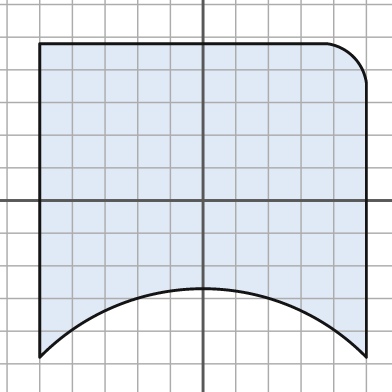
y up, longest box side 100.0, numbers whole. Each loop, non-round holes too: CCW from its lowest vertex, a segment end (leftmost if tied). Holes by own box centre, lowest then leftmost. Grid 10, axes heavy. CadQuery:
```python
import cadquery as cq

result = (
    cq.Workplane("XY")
    .moveTo(-50.0, -48.0)
    .threePointArc((0.0, -27.0), (50.0, -48.0))
    .lineTo(50.0, 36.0)
    .threePointArc((46.0, 44.0), (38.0, 48.0))
    .lineTo(-50.0, 48.0)
    .close()
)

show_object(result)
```